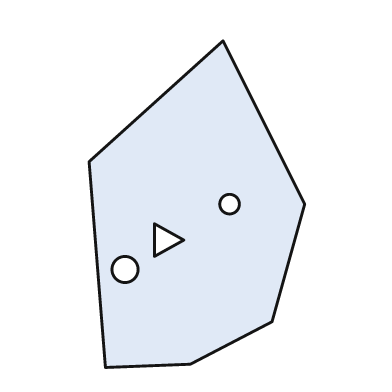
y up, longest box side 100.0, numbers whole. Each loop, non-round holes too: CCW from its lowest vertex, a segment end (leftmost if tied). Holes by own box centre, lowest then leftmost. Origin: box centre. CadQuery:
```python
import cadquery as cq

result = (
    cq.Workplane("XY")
    .moveTo(-28.0, -50.0)
    .lineTo(-2.0, -49.0)
    .lineTo(23.0, -36.0)
    .lineTo(33.0, 0.0)
    .lineTo(8.0, 50.0)
    .lineTo(-33.0, 13.0)
    .close()
    .moveTo(-22.0, -20.0)
    .circle(4.0)
    .moveTo(-13.0, -16.0)
    .lineTo(-4.0, -11.0)
    .lineTo(-13.0, -6.0)
    .close()
    .moveTo(10.0, 0.0)
    .circle(3.0)
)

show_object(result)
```